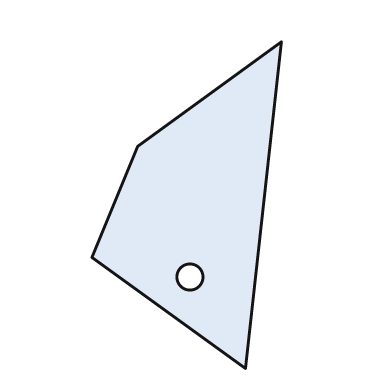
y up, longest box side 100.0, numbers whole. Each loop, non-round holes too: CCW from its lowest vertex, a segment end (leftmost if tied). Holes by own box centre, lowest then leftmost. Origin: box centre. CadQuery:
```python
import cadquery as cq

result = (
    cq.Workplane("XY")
    .moveTo(18.0, -50.0)
    .lineTo(29.0, 50.0)
    .lineTo(-15.0, 18.0)
    .lineTo(-29.0, -16.0)
    .close()
    .moveTo(1.0, -22.0)
    .circle(4.0)
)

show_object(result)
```